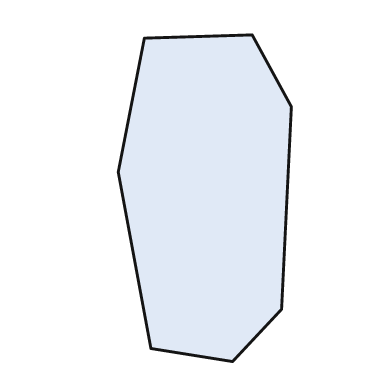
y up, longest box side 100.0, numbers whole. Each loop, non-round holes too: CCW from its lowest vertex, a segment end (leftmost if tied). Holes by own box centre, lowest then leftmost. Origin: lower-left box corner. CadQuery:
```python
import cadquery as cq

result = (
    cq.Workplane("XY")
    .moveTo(35.0, 0.0)
    .lineTo(50.0, 16.0)
    .lineTo(53.0, 78.0)
    .lineTo(41.0, 100.0)
    .lineTo(8.0, 99.0)
    .lineTo(0.0, 58.0)
    .lineTo(10.0, 4.0)
    .close()
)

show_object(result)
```